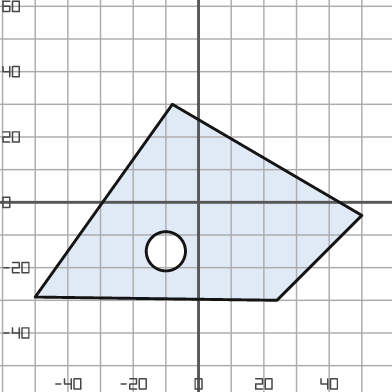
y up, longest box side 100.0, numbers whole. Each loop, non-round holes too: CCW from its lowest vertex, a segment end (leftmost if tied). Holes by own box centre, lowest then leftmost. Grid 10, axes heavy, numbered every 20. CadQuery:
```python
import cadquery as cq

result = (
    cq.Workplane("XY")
    .moveTo(24.0, -30.0)
    .lineTo(50.0, -4.0)
    .lineTo(-8.0, 30.0)
    .lineTo(-50.0, -29.0)
    .close()
    .moveTo(-10.0, -15.0)
    .circle(6.0)
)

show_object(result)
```